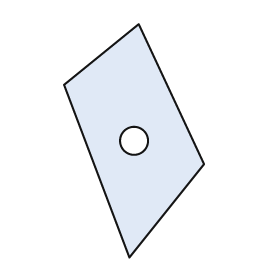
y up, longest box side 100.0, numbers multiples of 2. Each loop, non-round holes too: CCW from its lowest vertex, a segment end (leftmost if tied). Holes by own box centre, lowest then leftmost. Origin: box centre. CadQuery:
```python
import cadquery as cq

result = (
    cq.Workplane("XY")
    .moveTo(-2.0, -50.0)
    .lineTo(30.0, -10.0)
    .lineTo(2.0, 50.0)
    .lineTo(-30.0, 24.0)
    .close()
    .moveTo(0.0, 0.0)
    .circle(6.0)
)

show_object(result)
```